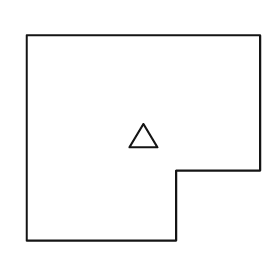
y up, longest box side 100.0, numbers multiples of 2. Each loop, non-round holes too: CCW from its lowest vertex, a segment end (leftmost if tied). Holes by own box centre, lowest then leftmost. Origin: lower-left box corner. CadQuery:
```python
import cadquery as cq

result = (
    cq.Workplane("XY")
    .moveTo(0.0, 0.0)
    .lineTo(64.0, 0.0)
    .lineTo(64.0, 30.0)
    .lineTo(100.0, 30.0)
    .lineTo(100.0, 88.0)
    .lineTo(0.0, 88.0)
    .close()
    .moveTo(44.0, 40.0)
    .lineTo(56.0, 40.0)
    .lineTo(50.0, 50.0)
    .close()
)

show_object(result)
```